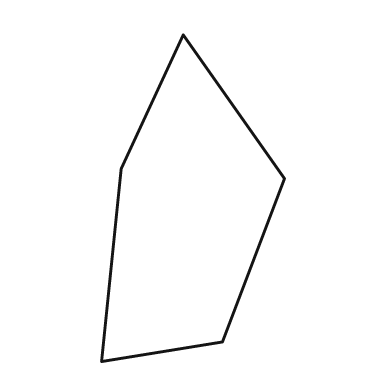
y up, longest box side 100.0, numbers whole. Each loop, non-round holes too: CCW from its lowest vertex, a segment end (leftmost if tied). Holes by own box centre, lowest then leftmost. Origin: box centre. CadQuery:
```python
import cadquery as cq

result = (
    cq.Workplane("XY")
    .moveTo(-28.0, -50.0)
    .lineTo(9.0, -44.0)
    .lineTo(28.0, 6.0)
    .lineTo(-3.0, 50.0)
    .lineTo(-22.0, 9.0)
    .close()
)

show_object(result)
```